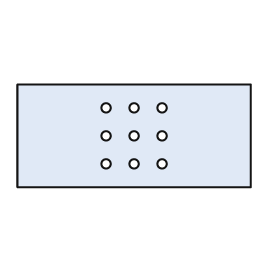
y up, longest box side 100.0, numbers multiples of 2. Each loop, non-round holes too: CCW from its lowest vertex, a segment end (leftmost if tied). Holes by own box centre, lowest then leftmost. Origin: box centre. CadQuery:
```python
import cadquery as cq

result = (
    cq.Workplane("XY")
    .moveTo(-50.0, -22.0)
    .lineTo(50.0, -22.0)
    .lineTo(50.0, 22.0)
    .lineTo(-50.0, 22.0)
    .close()
    .moveTo(-12.0, -12.0)
    .circle(2.0)
    .moveTo(0.0, -12.0)
    .circle(2.0)
    .moveTo(12.0, -12.0)
    .circle(2.0)
    .moveTo(-12.0, 0.0)
    .circle(2.0)
    .moveTo(0.0, 0.0)
    .circle(2.0)
    .moveTo(12.0, 0.0)
    .circle(2.0)
    .moveTo(-12.0, 12.0)
    .circle(2.0)
    .moveTo(0.0, 12.0)
    .circle(2.0)
    .moveTo(12.0, 12.0)
    .circle(2.0)
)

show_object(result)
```